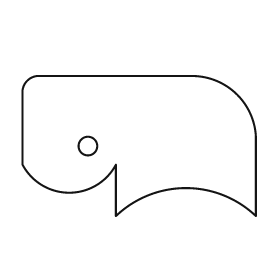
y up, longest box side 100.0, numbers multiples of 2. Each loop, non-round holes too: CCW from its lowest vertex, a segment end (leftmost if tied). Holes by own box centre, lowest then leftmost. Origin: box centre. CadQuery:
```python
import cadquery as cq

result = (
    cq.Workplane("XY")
    .moveTo(-10.0, -30.0)
    .threePointArc((20.0, -18.0), (50.0, -30.0))
    .lineTo(50.0, 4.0)
    .threePointArc((42.0, 22.0), (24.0, 30.0))
    .lineTo(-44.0, 30.0)
    .threePointArc((-48.0, 28.0), (-50.0, 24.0))
    .lineTo(-50.0, -8.0)
    .threePointArc((-30.0, -20.0), (-10.0, -8.0))
    .close()
    .moveTo(-22.0, 0.0)
    .circle(4.0)
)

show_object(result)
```